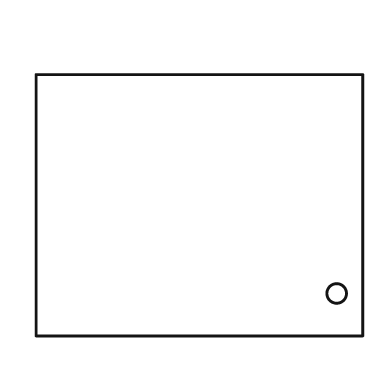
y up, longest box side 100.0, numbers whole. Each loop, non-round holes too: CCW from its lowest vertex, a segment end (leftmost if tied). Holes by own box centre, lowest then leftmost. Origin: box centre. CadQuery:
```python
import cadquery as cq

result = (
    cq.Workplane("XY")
    .moveTo(-50.0, -40.0)
    .lineTo(50.0, -40.0)
    .lineTo(50.0, 40.0)
    .lineTo(-50.0, 40.0)
    .close()
    .moveTo(42.0, -27.0)
    .circle(3.0)
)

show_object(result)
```